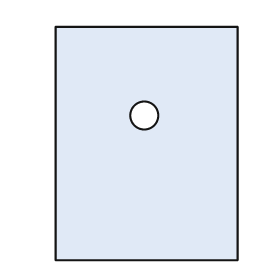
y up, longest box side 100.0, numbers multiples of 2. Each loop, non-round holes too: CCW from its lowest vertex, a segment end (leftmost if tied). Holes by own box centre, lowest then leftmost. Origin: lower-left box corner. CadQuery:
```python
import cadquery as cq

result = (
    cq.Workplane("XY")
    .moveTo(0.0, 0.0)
    .lineTo(78.0, 0.0)
    .lineTo(78.0, 100.0)
    .lineTo(0.0, 100.0)
    .close()
    .moveTo(38.0, 62.0)
    .circle(6.0)
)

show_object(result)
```